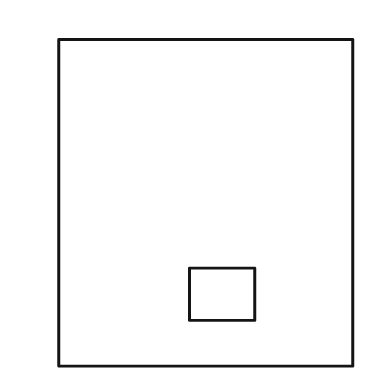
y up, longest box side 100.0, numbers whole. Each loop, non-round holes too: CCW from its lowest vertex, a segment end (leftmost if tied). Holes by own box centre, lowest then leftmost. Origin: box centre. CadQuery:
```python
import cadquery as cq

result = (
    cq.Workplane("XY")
    .moveTo(-45.0, -50.0)
    .lineTo(45.0, -50.0)
    .lineTo(45.0, 50.0)
    .lineTo(-45.0, 50.0)
    .close()
    .moveTo(-5.0, -36.0)
    .lineTo(15.0, -36.0)
    .lineTo(15.0, -20.0)
    .lineTo(-5.0, -20.0)
    .close()
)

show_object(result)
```